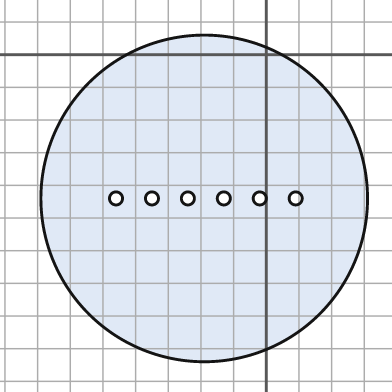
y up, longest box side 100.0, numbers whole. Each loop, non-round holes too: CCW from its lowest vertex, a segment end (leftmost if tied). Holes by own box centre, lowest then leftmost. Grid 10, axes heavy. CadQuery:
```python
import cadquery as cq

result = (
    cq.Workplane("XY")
    .moveTo(-19.0, -44.0)
    .circle(50.0)
    .moveTo(-46.0, -44.0)
    .circle(2.0)
    .moveTo(-35.0, -44.0)
    .circle(2.0)
    .moveTo(-24.0, -44.0)
    .circle(2.0)
    .moveTo(-13.0, -44.0)
    .circle(2.0)
    .moveTo(-2.0, -44.0)
    .circle(2.0)
    .moveTo(9.0, -44.0)
    .circle(2.0)
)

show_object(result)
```